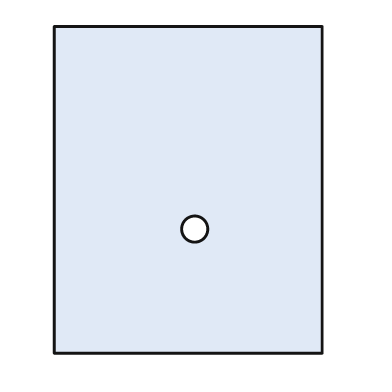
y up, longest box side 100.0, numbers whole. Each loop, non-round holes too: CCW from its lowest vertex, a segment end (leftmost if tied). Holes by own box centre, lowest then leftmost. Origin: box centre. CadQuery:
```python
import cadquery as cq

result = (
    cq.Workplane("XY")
    .moveTo(-41.0, -50.0)
    .lineTo(41.0, -50.0)
    .lineTo(41.0, 50.0)
    .lineTo(-41.0, 50.0)
    .close()
    .moveTo(2.0, -12.0)
    .circle(4.0)
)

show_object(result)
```